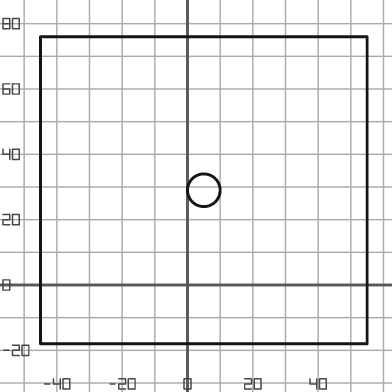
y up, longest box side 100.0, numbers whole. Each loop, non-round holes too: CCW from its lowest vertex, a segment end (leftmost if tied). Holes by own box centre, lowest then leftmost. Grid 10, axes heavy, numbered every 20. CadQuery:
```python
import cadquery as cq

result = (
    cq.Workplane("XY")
    .moveTo(-45.0, -18.0)
    .lineTo(55.0, -18.0)
    .lineTo(55.0, 76.0)
    .lineTo(-45.0, 76.0)
    .close()
    .moveTo(5.0, 29.0)
    .circle(5.0)
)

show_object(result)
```